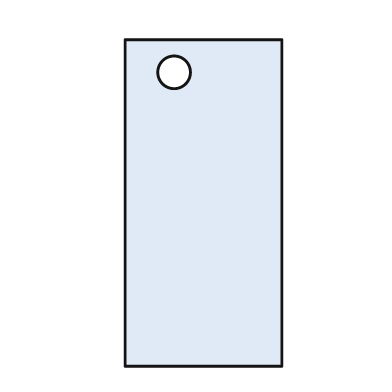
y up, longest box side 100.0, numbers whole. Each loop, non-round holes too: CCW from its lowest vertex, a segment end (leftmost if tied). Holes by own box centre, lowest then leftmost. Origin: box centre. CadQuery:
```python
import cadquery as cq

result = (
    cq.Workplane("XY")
    .moveTo(-24.0, -50.0)
    .lineTo(24.0, -50.0)
    .lineTo(24.0, 50.0)
    .lineTo(-24.0, 50.0)
    .close()
    .moveTo(-9.0, 40.0)
    .circle(5.0)
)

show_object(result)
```